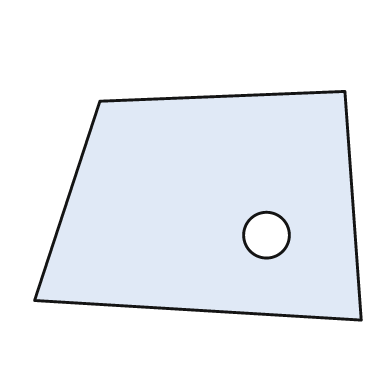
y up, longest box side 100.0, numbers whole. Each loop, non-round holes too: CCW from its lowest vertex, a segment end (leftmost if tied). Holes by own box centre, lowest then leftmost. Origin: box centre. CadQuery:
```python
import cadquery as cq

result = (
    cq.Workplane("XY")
    .moveTo(50.0, -35.0)
    .lineTo(45.0, 35.0)
    .lineTo(-30.0, 32.0)
    .lineTo(-50.0, -29.0)
    .close()
    .moveTo(21.0, -9.0)
    .circle(7.0)
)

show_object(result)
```